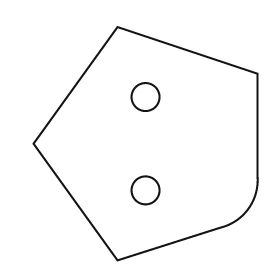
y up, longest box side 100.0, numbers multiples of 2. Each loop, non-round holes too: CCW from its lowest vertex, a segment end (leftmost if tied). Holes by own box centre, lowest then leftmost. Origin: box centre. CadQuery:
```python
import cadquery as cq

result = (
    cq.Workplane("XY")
    .moveTo(-12.0, -50.0)
    .lineTo(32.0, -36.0)
    .threePointArc((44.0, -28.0), (48.0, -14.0))
    .lineTo(48.0, 30.0)
    .lineTo(-12.0, 50.0)
    .lineTo(-48.0, 0.0)
    .close()
    .moveTo(0.0, -20.0)
    .circle(6.0)
    .moveTo(0.0, 20.0)
    .circle(6.0)
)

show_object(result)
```